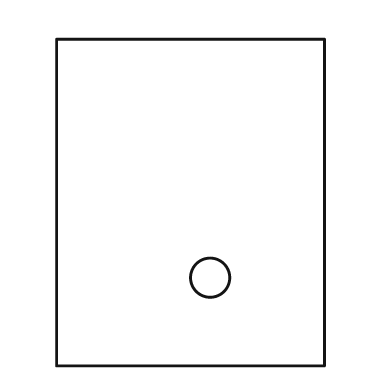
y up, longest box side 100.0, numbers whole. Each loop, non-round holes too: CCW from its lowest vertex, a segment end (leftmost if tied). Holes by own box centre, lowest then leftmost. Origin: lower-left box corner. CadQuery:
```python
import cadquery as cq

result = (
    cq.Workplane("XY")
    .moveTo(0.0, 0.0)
    .lineTo(82.0, 0.0)
    .lineTo(82.0, 100.0)
    .lineTo(0.0, 100.0)
    .close()
    .moveTo(47.0, 27.0)
    .circle(6.0)
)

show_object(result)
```